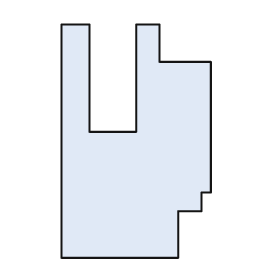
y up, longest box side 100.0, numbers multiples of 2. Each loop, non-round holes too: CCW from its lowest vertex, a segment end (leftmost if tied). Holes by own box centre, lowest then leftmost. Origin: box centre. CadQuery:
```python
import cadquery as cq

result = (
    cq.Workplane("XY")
    .moveTo(-32.0, -50.0)
    .lineTo(18.0, -50.0)
    .lineTo(18.0, -30.0)
    .lineTo(28.0, -30.0)
    .lineTo(28.0, -22.0)
    .lineTo(32.0, -22.0)
    .lineTo(32.0, 34.0)
    .lineTo(10.0, 34.0)
    .lineTo(10.0, 50.0)
    .lineTo(0.0, 50.0)
    .lineTo(0.0, 4.0)
    .lineTo(-20.0, 4.0)
    .lineTo(-20.0, 50.0)
    .lineTo(-32.0, 50.0)
    .close()
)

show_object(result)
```